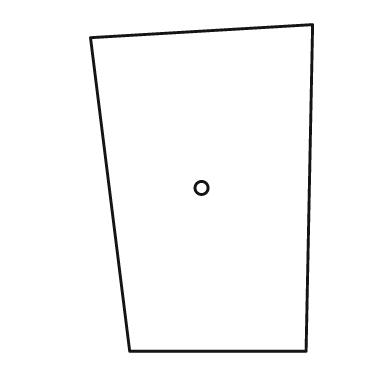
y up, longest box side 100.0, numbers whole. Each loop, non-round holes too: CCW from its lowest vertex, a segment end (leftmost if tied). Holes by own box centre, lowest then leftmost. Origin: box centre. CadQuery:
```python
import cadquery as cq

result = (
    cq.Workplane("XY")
    .moveTo(-22.0, -50.0)
    .lineTo(32.0, -50.0)
    .lineTo(34.0, 50.0)
    .lineTo(-34.0, 46.0)
    .close()
    .moveTo(0.0, 0.0)
    .circle(2.0)
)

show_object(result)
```